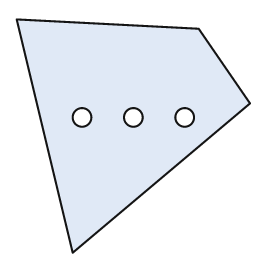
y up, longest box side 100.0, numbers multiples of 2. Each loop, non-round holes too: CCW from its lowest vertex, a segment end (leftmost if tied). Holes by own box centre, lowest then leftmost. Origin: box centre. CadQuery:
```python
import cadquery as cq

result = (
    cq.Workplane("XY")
    .moveTo(-26.0, -50.0)
    .lineTo(50.0, 14.0)
    .lineTo(28.0, 46.0)
    .lineTo(-50.0, 50.0)
    .close()
    .moveTo(-22.0, 8.0)
    .circle(4.0)
    .moveTo(0.0, 8.0)
    .circle(4.0)
    .moveTo(22.0, 8.0)
    .circle(4.0)
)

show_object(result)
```